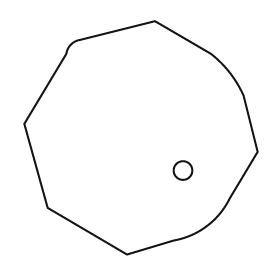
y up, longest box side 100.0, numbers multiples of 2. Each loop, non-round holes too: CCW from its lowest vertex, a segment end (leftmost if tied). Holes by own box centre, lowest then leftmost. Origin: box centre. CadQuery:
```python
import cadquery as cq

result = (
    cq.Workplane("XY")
    .moveTo(-6.0, -50.0)
    .lineTo(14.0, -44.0)
    .threePointArc((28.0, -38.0), (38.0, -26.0))
    .lineTo(50.0, -6.0)
    .lineTo(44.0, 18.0)
    .threePointArc((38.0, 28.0), (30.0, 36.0))
    .lineTo(6.0, 50.0)
    .lineTo(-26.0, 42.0)
    .threePointArc((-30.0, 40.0), (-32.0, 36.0))
    .lineTo(-50.0, 6.0)
    .lineTo(-40.0, -30.0)
    .close()
    .moveTo(18.0, -14.0)
    .circle(4.0)
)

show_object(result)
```